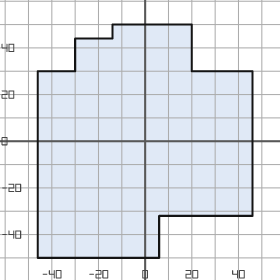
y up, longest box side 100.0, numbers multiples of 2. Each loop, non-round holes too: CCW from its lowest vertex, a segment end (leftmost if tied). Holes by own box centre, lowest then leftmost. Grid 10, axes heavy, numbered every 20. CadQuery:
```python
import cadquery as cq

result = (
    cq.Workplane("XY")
    .moveTo(-46.0, -50.0)
    .lineTo(6.0, -50.0)
    .lineTo(6.0, -32.0)
    .lineTo(46.0, -32.0)
    .lineTo(46.0, 30.0)
    .lineTo(20.0, 30.0)
    .lineTo(20.0, 50.0)
    .lineTo(-14.0, 50.0)
    .lineTo(-14.0, 44.0)
    .lineTo(-30.0, 44.0)
    .lineTo(-30.0, 30.0)
    .lineTo(-46.0, 30.0)
    .close()
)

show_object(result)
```